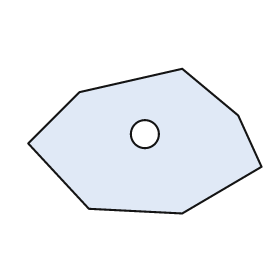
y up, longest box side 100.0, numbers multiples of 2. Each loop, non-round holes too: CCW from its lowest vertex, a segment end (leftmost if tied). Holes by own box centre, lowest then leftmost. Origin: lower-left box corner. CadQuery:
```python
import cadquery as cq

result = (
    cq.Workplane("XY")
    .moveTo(66.0, 0.0)
    .lineTo(100.0, 20.0)
    .lineTo(90.0, 42.0)
    .lineTo(66.0, 62.0)
    .lineTo(22.0, 52.0)
    .lineTo(0.0, 30.0)
    .lineTo(26.0, 2.0)
    .close()
    .moveTo(50.0, 34.0)
    .circle(6.0)
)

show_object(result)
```